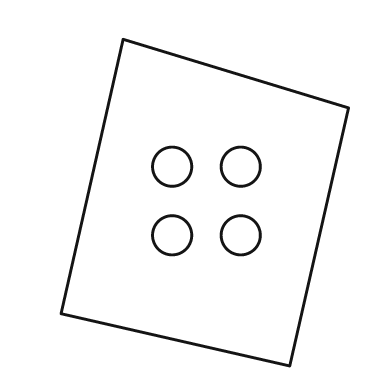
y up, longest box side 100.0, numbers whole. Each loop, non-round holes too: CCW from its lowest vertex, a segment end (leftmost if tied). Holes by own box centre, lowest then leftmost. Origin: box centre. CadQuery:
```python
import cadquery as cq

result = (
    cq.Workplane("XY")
    .moveTo(26.0, -50.0)
    .lineTo(44.0, 29.0)
    .lineTo(-25.0, 50.0)
    .lineTo(-44.0, -34.0)
    .close()
    .moveTo(-10.0, -10.0)
    .circle(6.0)
    .moveTo(11.0, -10.0)
    .circle(6.0)
    .moveTo(-10.0, 11.0)
    .circle(6.0)
    .moveTo(11.0, 11.0)
    .circle(6.0)
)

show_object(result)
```